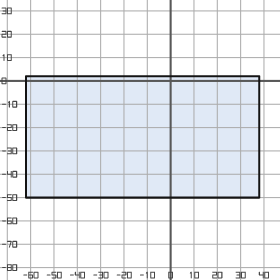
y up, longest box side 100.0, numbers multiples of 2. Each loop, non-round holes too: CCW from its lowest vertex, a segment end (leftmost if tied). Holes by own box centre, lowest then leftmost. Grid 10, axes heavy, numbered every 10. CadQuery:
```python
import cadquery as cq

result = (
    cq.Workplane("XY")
    .moveTo(-62.0, -50.0)
    .lineTo(38.0, -50.0)
    .lineTo(38.0, 2.0)
    .lineTo(-62.0, 2.0)
    .close()
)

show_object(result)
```